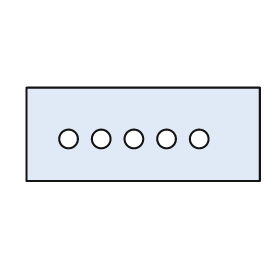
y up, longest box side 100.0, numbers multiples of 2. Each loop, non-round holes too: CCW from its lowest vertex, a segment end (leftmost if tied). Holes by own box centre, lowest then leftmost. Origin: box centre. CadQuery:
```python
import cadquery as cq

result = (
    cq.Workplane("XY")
    .moveTo(-50.0, -20.0)
    .lineTo(50.0, -20.0)
    .lineTo(50.0, 20.0)
    .lineTo(-50.0, 20.0)
    .close()
    .moveTo(-32.0, -2.0)
    .circle(4.0)
    .moveTo(-18.0, -2.0)
    .circle(4.0)
    .moveTo(-4.0, -2.0)
    .circle(4.0)
    .moveTo(10.0, -2.0)
    .circle(4.0)
    .moveTo(24.0, -2.0)
    .circle(4.0)
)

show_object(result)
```